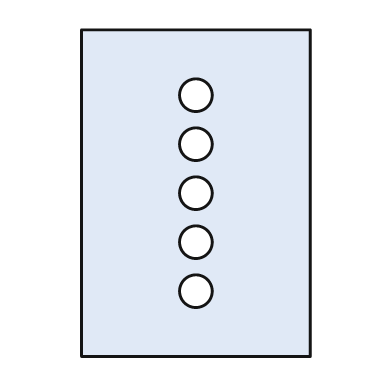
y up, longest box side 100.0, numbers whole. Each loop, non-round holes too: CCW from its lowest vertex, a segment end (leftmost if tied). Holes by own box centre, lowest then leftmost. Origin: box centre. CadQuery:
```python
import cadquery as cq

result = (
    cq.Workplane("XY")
    .moveTo(-35.0, -50.0)
    .lineTo(35.0, -50.0)
    .lineTo(35.0, 50.0)
    .lineTo(-35.0, 50.0)
    .close()
    .moveTo(0.0, -30.0)
    .circle(5.0)
    .moveTo(0.0, -15.0)
    .circle(5.0)
    .moveTo(0.0, 0.0)
    .circle(5.0)
    .moveTo(0.0, 15.0)
    .circle(5.0)
    .moveTo(0.0, 30.0)
    .circle(5.0)
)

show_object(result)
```